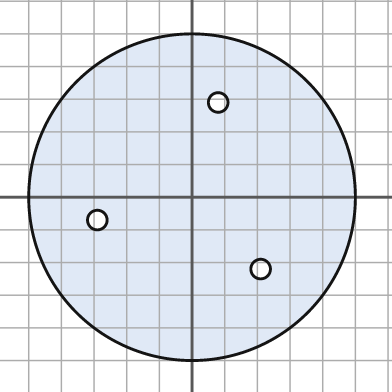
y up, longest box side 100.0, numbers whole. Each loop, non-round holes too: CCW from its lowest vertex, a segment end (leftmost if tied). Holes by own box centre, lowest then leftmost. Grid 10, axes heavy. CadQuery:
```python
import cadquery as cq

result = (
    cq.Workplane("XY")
    .moveTo(0.0, 0.0)
    .circle(50.0)
    .moveTo(21.0, -22.0)
    .circle(3.0)
    .moveTo(-29.0, -7.0)
    .circle(3.0)
    .moveTo(8.0, 29.0)
    .circle(3.0)
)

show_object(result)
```